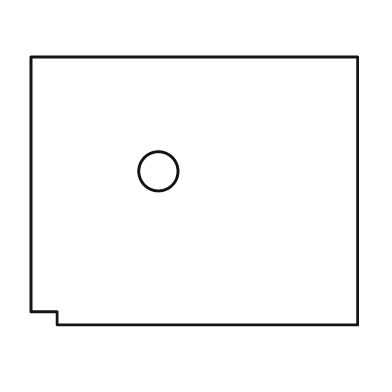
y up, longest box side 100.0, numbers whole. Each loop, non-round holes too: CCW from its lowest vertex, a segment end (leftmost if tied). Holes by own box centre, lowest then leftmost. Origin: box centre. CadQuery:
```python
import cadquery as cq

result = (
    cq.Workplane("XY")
    .moveTo(-42.0, -41.0)
    .lineTo(50.0, -41.0)
    .lineTo(50.0, 41.0)
    .lineTo(-50.0, 41.0)
    .lineTo(-50.0, -37.0)
    .lineTo(-42.0, -37.0)
    .close()
    .moveTo(-11.0, 6.0)
    .circle(6.0)
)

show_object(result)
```